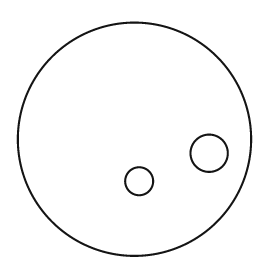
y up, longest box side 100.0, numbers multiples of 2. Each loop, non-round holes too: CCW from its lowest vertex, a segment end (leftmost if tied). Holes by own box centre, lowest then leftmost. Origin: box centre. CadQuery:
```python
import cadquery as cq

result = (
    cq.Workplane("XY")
    .moveTo(0.0, 0.0)
    .circle(50.0)
    .moveTo(2.0, -18.0)
    .circle(6.0)
    .moveTo(32.0, -6.0)
    .circle(8.0)
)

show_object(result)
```